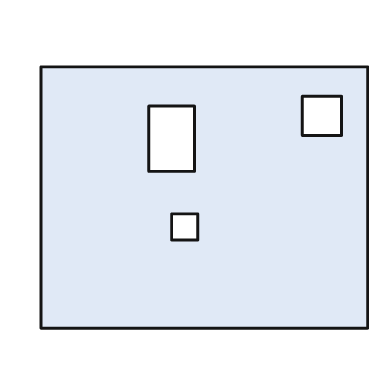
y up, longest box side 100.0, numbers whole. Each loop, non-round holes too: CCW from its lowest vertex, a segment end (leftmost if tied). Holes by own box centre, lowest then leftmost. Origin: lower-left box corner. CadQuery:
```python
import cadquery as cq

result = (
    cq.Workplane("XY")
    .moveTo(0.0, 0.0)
    .lineTo(100.0, 0.0)
    .lineTo(100.0, 80.0)
    .lineTo(0.0, 80.0)
    .close()
    .moveTo(40.0, 27.0)
    .lineTo(48.0, 27.0)
    .lineTo(48.0, 35.0)
    .lineTo(40.0, 35.0)
    .close()
    .moveTo(33.0, 48.0)
    .lineTo(47.0, 48.0)
    .lineTo(47.0, 68.0)
    .lineTo(33.0, 68.0)
    .close()
    .moveTo(80.0, 59.0)
    .lineTo(92.0, 59.0)
    .lineTo(92.0, 71.0)
    .lineTo(80.0, 71.0)
    .close()
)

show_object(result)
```